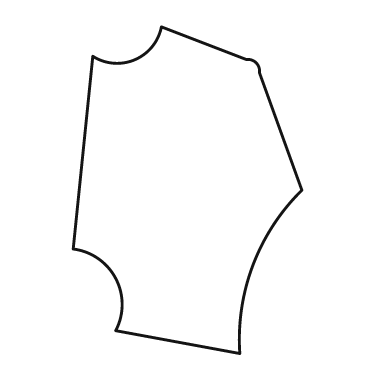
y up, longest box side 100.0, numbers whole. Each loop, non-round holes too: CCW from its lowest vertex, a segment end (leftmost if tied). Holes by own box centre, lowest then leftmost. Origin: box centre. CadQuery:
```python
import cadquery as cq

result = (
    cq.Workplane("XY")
    .moveTo(16.0, -50.0)
    .threePointArc((20.0, -23.0), (35.0, 0.0))
    .lineTo(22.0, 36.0)
    .threePointArc((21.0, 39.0), (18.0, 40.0))
    .lineTo(-8.0, 50.0)
    .threePointArc((-16.0, 40.0), (-29.0, 41.0))
    .lineTo(-35.0, -18.0)
    .threePointArc((-22.0, -27.0), (-22.0, -43.0))
    .close()
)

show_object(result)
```